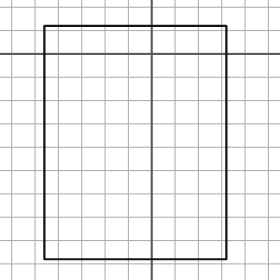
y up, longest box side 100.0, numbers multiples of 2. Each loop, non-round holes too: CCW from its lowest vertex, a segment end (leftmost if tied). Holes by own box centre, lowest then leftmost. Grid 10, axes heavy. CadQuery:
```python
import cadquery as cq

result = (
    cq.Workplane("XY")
    .moveTo(-46.0, -88.0)
    .lineTo(32.0, -88.0)
    .lineTo(32.0, 12.0)
    .lineTo(-46.0, 12.0)
    .close()
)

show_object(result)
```